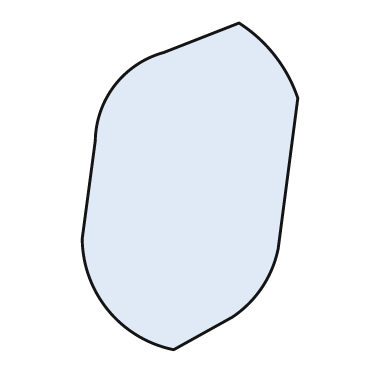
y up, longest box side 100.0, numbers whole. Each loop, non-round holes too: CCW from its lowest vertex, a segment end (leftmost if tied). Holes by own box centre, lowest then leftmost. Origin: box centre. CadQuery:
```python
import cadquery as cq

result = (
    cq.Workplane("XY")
    .moveTo(-5.0, -50.0)
    .lineTo(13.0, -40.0)
    .threePointArc((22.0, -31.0), (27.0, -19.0))
    .lineTo(33.0, 27.0)
    .threePointArc((26.0, 40.0), (15.0, 50.0))
    .lineTo(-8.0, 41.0)
    .threePointArc((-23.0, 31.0), (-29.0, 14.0))
    .lineTo(-33.0, -16.0)
    .threePointArc((-25.0, -38.0), (-5.0, -50.0))
    .close()
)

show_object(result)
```